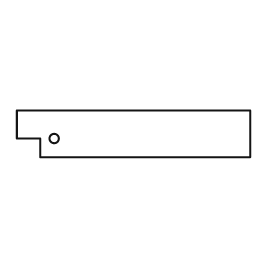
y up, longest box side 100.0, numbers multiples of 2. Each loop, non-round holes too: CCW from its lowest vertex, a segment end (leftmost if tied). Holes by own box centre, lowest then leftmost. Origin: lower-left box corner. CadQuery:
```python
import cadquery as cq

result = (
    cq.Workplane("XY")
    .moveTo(10.0, 0.0)
    .lineTo(100.0, 0.0)
    .lineTo(100.0, 20.0)
    .lineTo(0.0, 20.0)
    .lineTo(0.0, 8.0)
    .lineTo(10.0, 8.0)
    .close()
    .moveTo(16.0, 8.0)
    .circle(2.0)
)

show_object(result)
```